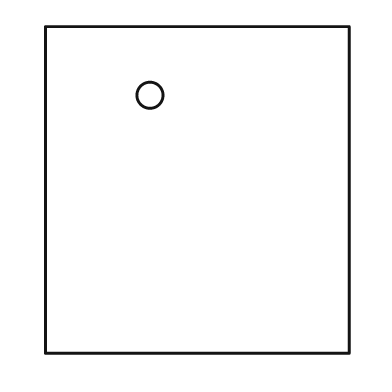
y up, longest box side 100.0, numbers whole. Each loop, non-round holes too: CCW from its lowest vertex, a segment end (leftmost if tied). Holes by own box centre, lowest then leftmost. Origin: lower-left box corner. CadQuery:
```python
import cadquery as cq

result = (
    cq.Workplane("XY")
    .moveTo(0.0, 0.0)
    .lineTo(93.0, 0.0)
    .lineTo(93.0, 100.0)
    .lineTo(0.0, 100.0)
    .close()
    .moveTo(32.0, 79.0)
    .circle(4.0)
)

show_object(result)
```